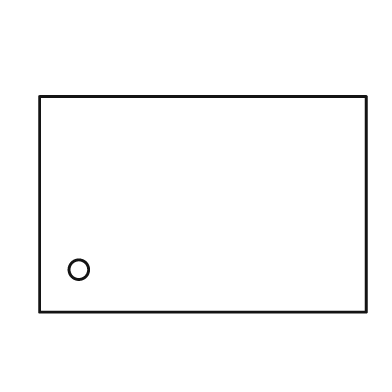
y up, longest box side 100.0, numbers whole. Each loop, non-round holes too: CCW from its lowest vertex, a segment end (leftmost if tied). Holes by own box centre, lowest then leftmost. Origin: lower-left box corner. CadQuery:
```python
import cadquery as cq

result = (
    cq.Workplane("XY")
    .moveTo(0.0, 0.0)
    .lineTo(100.0, 0.0)
    .lineTo(100.0, 66.0)
    .lineTo(0.0, 66.0)
    .close()
    .moveTo(12.0, 13.0)
    .circle(3.0)
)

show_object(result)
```